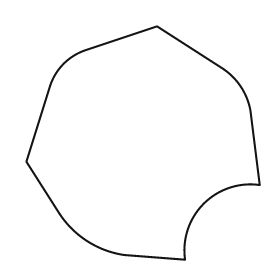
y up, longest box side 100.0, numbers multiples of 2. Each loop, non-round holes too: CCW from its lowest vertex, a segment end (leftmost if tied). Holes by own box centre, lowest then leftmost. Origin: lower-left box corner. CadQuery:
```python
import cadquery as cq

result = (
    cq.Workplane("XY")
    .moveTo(68.0, 0.0)
    .threePointArc((76.0, 24.0), (100.0, 32.0))
    .lineTo(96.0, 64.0)
    .threePointArc((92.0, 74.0), (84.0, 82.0))
    .lineTo(56.0, 100.0)
    .lineTo(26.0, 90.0)
    .threePointArc((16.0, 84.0), (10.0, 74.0))
    .lineTo(0.0, 42.0)
    .lineTo(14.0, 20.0)
    .threePointArc((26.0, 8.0), (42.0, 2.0))
    .close()
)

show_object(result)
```